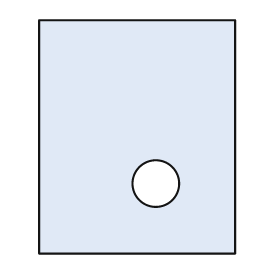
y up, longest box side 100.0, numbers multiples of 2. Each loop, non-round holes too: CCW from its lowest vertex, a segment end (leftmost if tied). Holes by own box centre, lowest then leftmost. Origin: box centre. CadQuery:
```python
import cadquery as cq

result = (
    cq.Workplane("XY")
    .moveTo(-42.0, -50.0)
    .lineTo(42.0, -50.0)
    .lineTo(42.0, 50.0)
    .lineTo(-42.0, 50.0)
    .close()
    .moveTo(8.0, -20.0)
    .circle(10.0)
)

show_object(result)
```